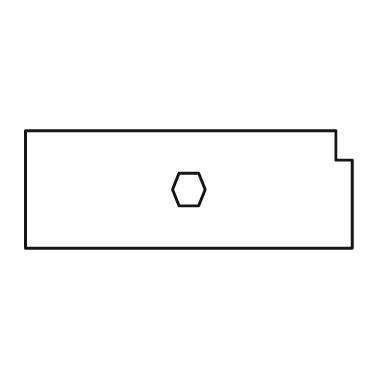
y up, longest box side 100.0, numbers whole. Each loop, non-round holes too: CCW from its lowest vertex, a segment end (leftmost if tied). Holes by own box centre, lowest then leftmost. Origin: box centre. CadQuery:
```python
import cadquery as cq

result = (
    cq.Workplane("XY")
    .moveTo(-50.0, -18.0)
    .lineTo(50.0, -18.0)
    .lineTo(50.0, 9.0)
    .lineTo(45.0, 9.0)
    .lineTo(45.0, 18.0)
    .lineTo(-50.0, 18.0)
    .close()
    .moveTo(-3.0, -5.0)
    .lineTo(3.0, -5.0)
    .lineTo(5.0, 0.0)
    .lineTo(3.0, 5.0)
    .lineTo(-3.0, 5.0)
    .lineTo(-5.0, 0.0)
    .close()
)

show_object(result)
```